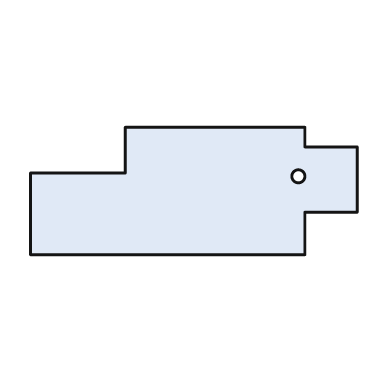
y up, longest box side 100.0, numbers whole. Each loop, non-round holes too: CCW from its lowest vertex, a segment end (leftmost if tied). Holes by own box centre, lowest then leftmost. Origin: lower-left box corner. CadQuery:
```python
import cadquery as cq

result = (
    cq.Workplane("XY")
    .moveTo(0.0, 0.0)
    .lineTo(84.0, 0.0)
    .lineTo(84.0, 13.0)
    .lineTo(100.0, 13.0)
    .lineTo(100.0, 33.0)
    .lineTo(84.0, 33.0)
    .lineTo(84.0, 39.0)
    .lineTo(29.0, 39.0)
    .lineTo(29.0, 25.0)
    .lineTo(0.0, 25.0)
    .close()
    .moveTo(82.0, 24.0)
    .circle(2.0)
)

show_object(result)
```